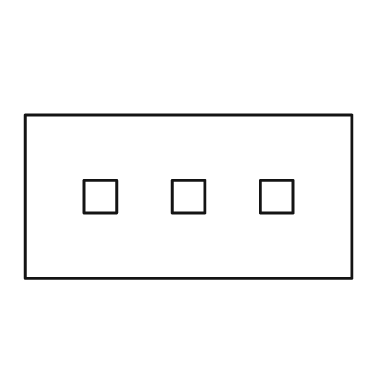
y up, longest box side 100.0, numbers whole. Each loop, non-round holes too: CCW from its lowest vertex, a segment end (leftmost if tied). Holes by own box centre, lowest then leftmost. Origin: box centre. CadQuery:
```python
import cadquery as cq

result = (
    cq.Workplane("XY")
    .moveTo(-50.0, -25.0)
    .lineTo(50.0, -25.0)
    .lineTo(50.0, 25.0)
    .lineTo(-50.0, 25.0)
    .close()
    .moveTo(-32.0, -5.0)
    .lineTo(-22.0, -5.0)
    .lineTo(-22.0, 5.0)
    .lineTo(-32.0, 5.0)
    .close()
    .moveTo(-5.0, -5.0)
    .lineTo(5.0, -5.0)
    .lineTo(5.0, 5.0)
    .lineTo(-5.0, 5.0)
    .close()
    .moveTo(22.0, -5.0)
    .lineTo(32.0, -5.0)
    .lineTo(32.0, 5.0)
    .lineTo(22.0, 5.0)
    .close()
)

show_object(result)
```